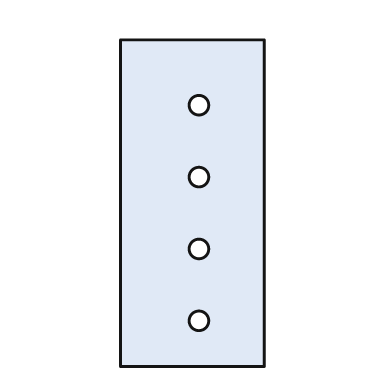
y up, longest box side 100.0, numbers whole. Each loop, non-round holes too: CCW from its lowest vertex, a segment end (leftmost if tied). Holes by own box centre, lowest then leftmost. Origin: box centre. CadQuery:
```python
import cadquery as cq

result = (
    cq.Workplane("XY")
    .moveTo(-22.0, -50.0)
    .lineTo(22.0, -50.0)
    .lineTo(22.0, 50.0)
    .lineTo(-22.0, 50.0)
    .close()
    .moveTo(2.0, -36.0)
    .circle(3.0)
    .moveTo(2.0, -14.0)
    .circle(3.0)
    .moveTo(2.0, 8.0)
    .circle(3.0)
    .moveTo(2.0, 30.0)
    .circle(3.0)
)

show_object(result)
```